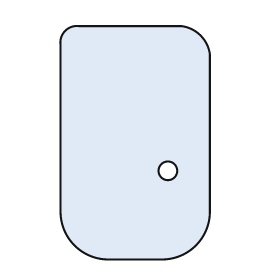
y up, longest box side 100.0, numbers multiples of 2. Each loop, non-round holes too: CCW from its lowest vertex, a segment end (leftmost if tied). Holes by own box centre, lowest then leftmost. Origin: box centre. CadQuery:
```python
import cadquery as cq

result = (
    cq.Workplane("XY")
    .moveTo(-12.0, -50.0)
    .lineTo(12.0, -50.0)
    .threePointArc((26.0, -44.0), (32.0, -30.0))
    .lineTo(32.0, 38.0)
    .threePointArc((28.0, 46.0), (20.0, 50.0))
    .lineTo(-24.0, 50.0)
    .threePointArc((-30.0, 48.0), (-32.0, 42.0))
    .lineTo(-32.0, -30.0)
    .threePointArc((-26.0, -44.0), (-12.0, -50.0))
    .close()
    .moveTo(14.0, -12.0)
    .circle(4.0)
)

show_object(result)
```